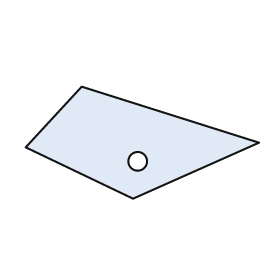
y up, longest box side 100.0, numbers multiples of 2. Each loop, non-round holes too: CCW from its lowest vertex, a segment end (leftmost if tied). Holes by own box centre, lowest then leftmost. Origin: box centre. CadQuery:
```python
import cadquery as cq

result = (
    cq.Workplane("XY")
    .moveTo(-4.0, -24.0)
    .lineTo(50.0, 0.0)
    .lineTo(-26.0, 24.0)
    .lineTo(-50.0, -2.0)
    .close()
    .moveTo(-2.0, -8.0)
    .circle(4.0)
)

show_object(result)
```